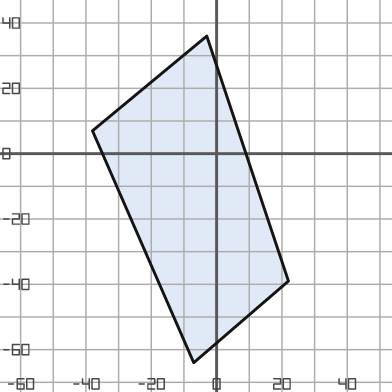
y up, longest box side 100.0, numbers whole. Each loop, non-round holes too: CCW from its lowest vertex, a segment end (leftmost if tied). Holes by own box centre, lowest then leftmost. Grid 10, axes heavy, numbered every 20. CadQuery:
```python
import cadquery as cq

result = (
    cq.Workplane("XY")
    .moveTo(-7.0, -64.0)
    .lineTo(22.0, -39.0)
    .lineTo(-3.0, 36.0)
    .lineTo(-38.0, 7.0)
    .close()
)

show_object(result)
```